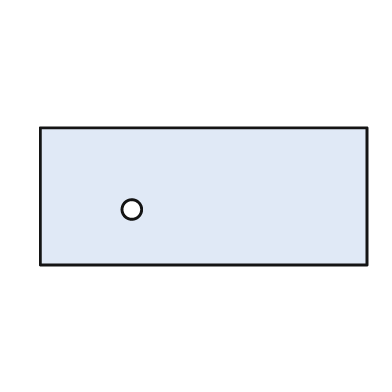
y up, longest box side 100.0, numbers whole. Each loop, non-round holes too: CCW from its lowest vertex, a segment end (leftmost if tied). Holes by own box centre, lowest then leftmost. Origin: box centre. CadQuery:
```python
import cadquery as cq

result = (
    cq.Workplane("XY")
    .moveTo(-50.0, -21.0)
    .lineTo(50.0, -21.0)
    .lineTo(50.0, 21.0)
    .lineTo(-50.0, 21.0)
    .close()
    .moveTo(-22.0, -4.0)
    .circle(3.0)
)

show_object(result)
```